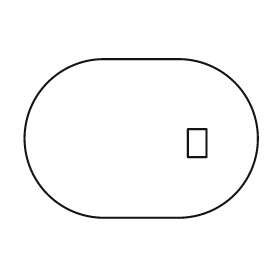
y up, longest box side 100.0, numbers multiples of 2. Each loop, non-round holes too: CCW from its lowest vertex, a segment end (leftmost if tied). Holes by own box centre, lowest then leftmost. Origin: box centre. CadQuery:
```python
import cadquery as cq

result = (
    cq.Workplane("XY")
    .moveTo(-16.0, -34.0)
    .lineTo(16.0, -34.0)
    .threePointArc((50.0, 0.0), (16.0, 34.0))
    .lineTo(-16.0, 34.0)
    .threePointArc((-50.0, 0.0), (-16.0, -34.0))
    .close()
    .moveTo(20.0, -8.0)
    .lineTo(28.0, -8.0)
    .lineTo(28.0, 4.0)
    .lineTo(20.0, 4.0)
    .close()
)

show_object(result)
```